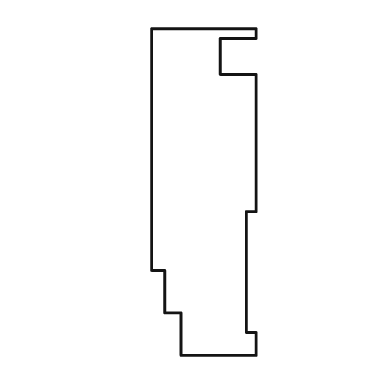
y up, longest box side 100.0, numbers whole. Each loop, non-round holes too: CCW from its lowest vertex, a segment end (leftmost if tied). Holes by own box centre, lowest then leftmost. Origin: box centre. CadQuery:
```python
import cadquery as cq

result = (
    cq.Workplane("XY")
    .moveTo(-7.0, -50.0)
    .lineTo(16.0, -50.0)
    .lineTo(16.0, -43.0)
    .lineTo(13.0, -43.0)
    .lineTo(13.0, -6.0)
    .lineTo(16.0, -6.0)
    .lineTo(16.0, 36.0)
    .lineTo(5.0, 36.0)
    .lineTo(5.0, 47.0)
    .lineTo(16.0, 47.0)
    .lineTo(16.0, 50.0)
    .lineTo(-16.0, 50.0)
    .lineTo(-16.0, -24.0)
    .lineTo(-12.0, -24.0)
    .lineTo(-12.0, -37.0)
    .lineTo(-7.0, -37.0)
    .close()
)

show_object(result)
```